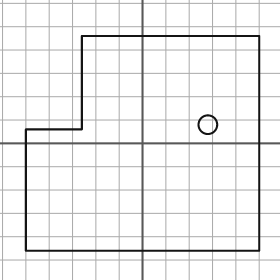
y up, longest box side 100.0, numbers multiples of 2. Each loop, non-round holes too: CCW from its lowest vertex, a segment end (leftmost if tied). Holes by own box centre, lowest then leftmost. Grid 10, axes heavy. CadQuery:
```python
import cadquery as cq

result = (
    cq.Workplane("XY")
    .moveTo(-50.0, -46.0)
    .lineTo(50.0, -46.0)
    .lineTo(50.0, 46.0)
    .lineTo(-26.0, 46.0)
    .lineTo(-26.0, 6.0)
    .lineTo(-50.0, 6.0)
    .close()
    .moveTo(28.0, 8.0)
    .circle(4.0)
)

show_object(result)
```